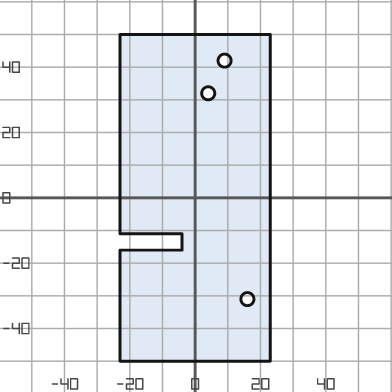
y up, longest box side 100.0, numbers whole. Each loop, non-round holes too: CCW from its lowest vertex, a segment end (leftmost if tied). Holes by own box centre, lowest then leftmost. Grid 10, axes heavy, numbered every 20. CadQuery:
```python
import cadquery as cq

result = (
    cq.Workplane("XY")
    .moveTo(-23.0, -50.0)
    .lineTo(23.0, -50.0)
    .lineTo(23.0, 50.0)
    .lineTo(-23.0, 50.0)
    .lineTo(-23.0, -11.0)
    .lineTo(-4.0, -11.0)
    .lineTo(-4.0, -16.0)
    .lineTo(-23.0, -16.0)
    .close()
    .moveTo(16.0, -31.0)
    .circle(2.0)
    .moveTo(4.0, 32.0)
    .circle(2.0)
    .moveTo(9.0, 42.0)
    .circle(2.0)
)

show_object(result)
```